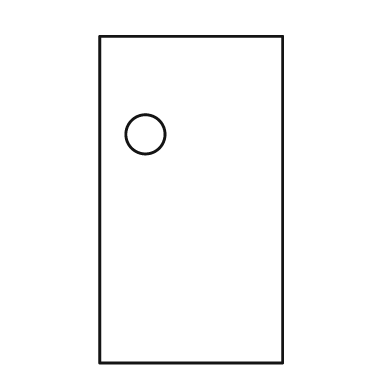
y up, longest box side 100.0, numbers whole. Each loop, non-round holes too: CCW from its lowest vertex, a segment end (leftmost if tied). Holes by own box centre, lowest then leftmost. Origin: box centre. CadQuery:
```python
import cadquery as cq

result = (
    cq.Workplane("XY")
    .moveTo(-28.0, -50.0)
    .lineTo(28.0, -50.0)
    .lineTo(28.0, 50.0)
    .lineTo(-28.0, 50.0)
    .close()
    .moveTo(-14.0, 20.0)
    .circle(6.0)
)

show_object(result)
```